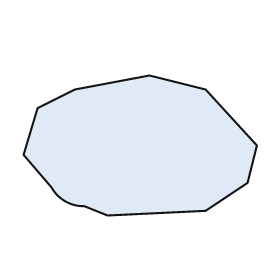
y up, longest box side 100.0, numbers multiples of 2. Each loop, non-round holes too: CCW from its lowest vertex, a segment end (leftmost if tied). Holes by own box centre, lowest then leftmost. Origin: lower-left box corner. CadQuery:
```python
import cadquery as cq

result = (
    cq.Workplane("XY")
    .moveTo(36.0, 0.0)
    .lineTo(78.0, 2.0)
    .lineTo(96.0, 14.0)
    .lineTo(100.0, 30.0)
    .lineTo(78.0, 54.0)
    .lineTo(54.0, 60.0)
    .lineTo(22.0, 54.0)
    .lineTo(6.0, 46.0)
    .lineTo(0.0, 26.0)
    .lineTo(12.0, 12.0)
    .threePointArc((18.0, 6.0), (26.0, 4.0))
    .close()
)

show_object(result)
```